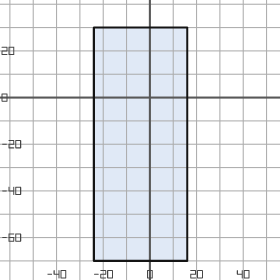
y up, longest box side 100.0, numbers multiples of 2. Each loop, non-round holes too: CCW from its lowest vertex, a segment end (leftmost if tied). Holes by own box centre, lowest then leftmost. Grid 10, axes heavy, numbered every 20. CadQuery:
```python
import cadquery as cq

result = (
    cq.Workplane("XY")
    .moveTo(-24.0, -70.0)
    .lineTo(16.0, -70.0)
    .lineTo(16.0, 30.0)
    .lineTo(-24.0, 30.0)
    .close()
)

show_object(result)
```